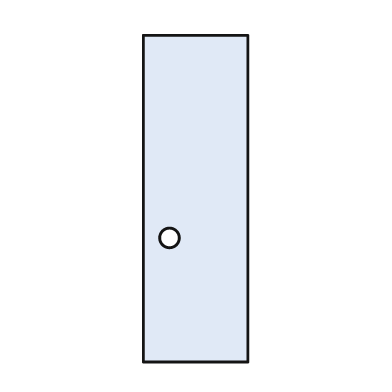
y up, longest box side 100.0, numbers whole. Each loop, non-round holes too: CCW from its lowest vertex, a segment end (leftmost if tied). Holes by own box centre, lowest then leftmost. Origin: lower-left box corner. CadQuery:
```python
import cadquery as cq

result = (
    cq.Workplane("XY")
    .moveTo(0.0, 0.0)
    .lineTo(32.0, 0.0)
    .lineTo(32.0, 100.0)
    .lineTo(0.0, 100.0)
    .close()
    .moveTo(8.0, 38.0)
    .circle(3.0)
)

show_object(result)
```